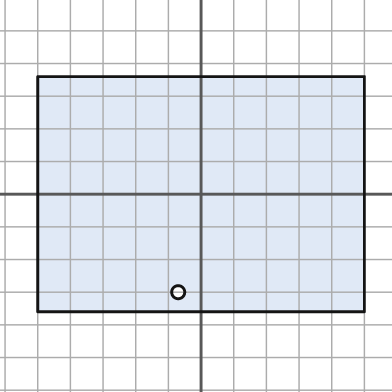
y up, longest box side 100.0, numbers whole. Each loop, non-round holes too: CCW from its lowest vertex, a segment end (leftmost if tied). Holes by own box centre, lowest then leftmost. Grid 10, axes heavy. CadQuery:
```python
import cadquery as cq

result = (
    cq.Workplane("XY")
    .moveTo(-50.0, -36.0)
    .lineTo(50.0, -36.0)
    .lineTo(50.0, 36.0)
    .lineTo(-50.0, 36.0)
    .close()
    .moveTo(-7.0, -30.0)
    .circle(2.0)
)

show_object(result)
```